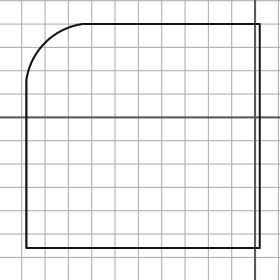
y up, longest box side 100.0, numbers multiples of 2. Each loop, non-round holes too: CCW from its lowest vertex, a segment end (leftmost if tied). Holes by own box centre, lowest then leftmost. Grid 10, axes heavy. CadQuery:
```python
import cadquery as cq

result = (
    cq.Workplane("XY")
    .moveTo(-98.0, -56.0)
    .lineTo(2.0, -56.0)
    .lineTo(2.0, 40.0)
    .lineTo(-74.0, 40.0)
    .threePointArc((-90.0, 32.0), (-98.0, 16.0))
    .close()
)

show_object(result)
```